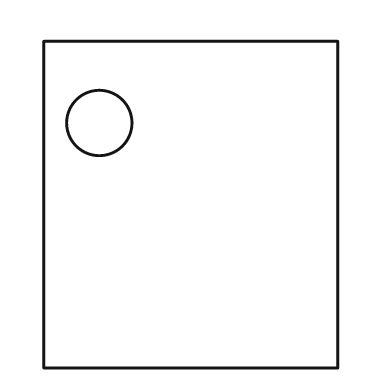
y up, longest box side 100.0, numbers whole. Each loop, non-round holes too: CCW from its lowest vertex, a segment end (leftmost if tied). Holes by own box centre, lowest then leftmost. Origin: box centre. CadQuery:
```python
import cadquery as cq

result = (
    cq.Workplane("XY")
    .moveTo(-45.0, -50.0)
    .lineTo(45.0, -50.0)
    .lineTo(45.0, 50.0)
    .lineTo(-45.0, 50.0)
    .close()
    .moveTo(-28.0, 25.0)
    .circle(10.0)
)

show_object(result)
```